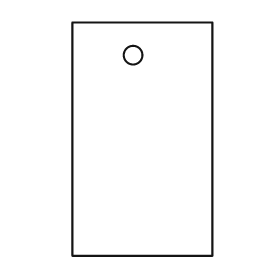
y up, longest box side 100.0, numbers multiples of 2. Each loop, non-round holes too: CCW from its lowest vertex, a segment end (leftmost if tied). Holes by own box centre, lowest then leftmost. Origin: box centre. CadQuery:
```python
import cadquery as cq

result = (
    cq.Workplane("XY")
    .moveTo(-30.0, -50.0)
    .lineTo(30.0, -50.0)
    .lineTo(30.0, 50.0)
    .lineTo(-30.0, 50.0)
    .close()
    .moveTo(-4.0, 36.0)
    .circle(4.0)
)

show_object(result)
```